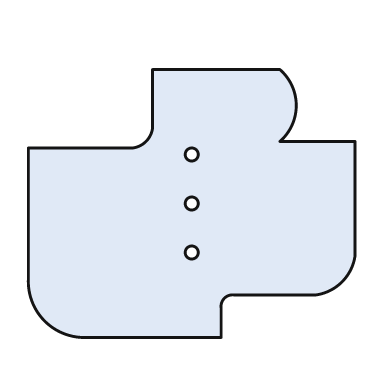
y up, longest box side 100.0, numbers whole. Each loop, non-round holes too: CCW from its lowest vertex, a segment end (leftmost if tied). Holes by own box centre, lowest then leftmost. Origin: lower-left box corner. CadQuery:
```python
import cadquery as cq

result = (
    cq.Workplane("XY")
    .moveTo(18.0, 0.0)
    .lineTo(59.0, 0.0)
    .lineTo(59.0, 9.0)
    .threePointArc((60.0, 12.0), (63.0, 13.0))
    .lineTo(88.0, 13.0)
    .threePointArc((96.0, 17.0), (100.0, 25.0))
    .lineTo(100.0, 60.0)
    .lineTo(77.0, 60.0)
    .threePointArc((82.0, 71.0), (77.0, 82.0))
    .lineTo(38.0, 82.0)
    .lineTo(38.0, 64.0)
    .threePointArc((36.0, 60.0), (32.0, 58.0))
    .lineTo(0.0, 58.0)
    .lineTo(0.0, 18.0)
    .threePointArc((5.0, 5.0), (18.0, 0.0))
    .close()
    .moveTo(50.0, 26.0)
    .circle(2.0)
    .moveTo(50.0, 41.0)
    .circle(2.0)
    .moveTo(50.0, 56.0)
    .circle(2.0)
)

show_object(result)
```